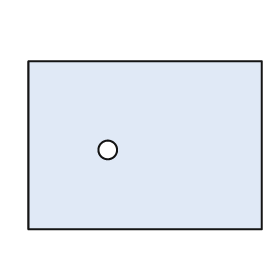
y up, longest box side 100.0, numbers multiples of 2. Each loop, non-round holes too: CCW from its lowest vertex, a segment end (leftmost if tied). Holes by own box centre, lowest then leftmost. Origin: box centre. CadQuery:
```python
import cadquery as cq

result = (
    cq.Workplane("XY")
    .moveTo(-50.0, -36.0)
    .lineTo(50.0, -36.0)
    .lineTo(50.0, 36.0)
    .lineTo(-50.0, 36.0)
    .close()
    .moveTo(-16.0, -2.0)
    .circle(4.0)
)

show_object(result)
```